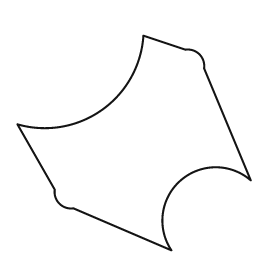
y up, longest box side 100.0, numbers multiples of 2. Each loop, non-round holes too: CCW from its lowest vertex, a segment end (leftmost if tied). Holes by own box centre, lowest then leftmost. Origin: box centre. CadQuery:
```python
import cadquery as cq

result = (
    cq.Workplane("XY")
    .moveTo(16.0, -46.0)
    .threePointArc((20.0, -16.0), (50.0, -16.0))
    .lineTo(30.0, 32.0)
    .threePointArc((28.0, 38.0), (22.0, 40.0))
    .lineTo(4.0, 46.0)
    .threePointArc((-14.0, 14.0), (-50.0, 8.0))
    .lineTo(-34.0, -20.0)
    .threePointArc((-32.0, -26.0), (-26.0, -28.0))
    .close()
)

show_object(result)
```